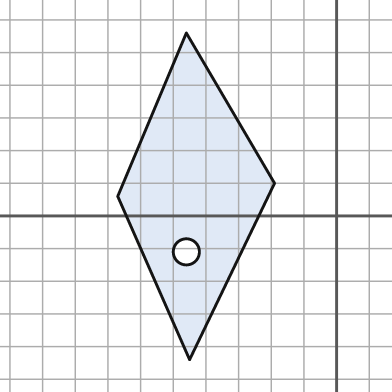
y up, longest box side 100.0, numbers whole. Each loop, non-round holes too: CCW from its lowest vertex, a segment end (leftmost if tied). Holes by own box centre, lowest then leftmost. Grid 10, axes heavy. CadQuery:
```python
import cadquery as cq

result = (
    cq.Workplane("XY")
    .moveTo(-45.0, -44.0)
    .lineTo(-19.0, 10.0)
    .lineTo(-46.0, 56.0)
    .lineTo(-67.0, 6.0)
    .close()
    .moveTo(-46.0, -11.0)
    .circle(4.0)
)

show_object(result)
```